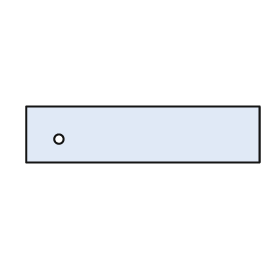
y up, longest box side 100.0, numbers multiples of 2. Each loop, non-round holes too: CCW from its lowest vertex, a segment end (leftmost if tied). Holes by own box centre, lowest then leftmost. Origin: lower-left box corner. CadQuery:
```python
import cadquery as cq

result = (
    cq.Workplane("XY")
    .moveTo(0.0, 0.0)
    .lineTo(100.0, 0.0)
    .lineTo(100.0, 24.0)
    .lineTo(0.0, 24.0)
    .close()
    .moveTo(14.0, 10.0)
    .circle(2.0)
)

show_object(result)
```